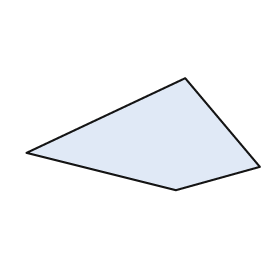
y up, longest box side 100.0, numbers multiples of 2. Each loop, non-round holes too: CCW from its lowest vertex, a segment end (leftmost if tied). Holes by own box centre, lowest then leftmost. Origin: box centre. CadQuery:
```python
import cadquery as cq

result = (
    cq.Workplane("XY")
    .moveTo(14.0, -24.0)
    .lineTo(50.0, -14.0)
    .lineTo(18.0, 24.0)
    .lineTo(-50.0, -8.0)
    .close()
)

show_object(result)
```